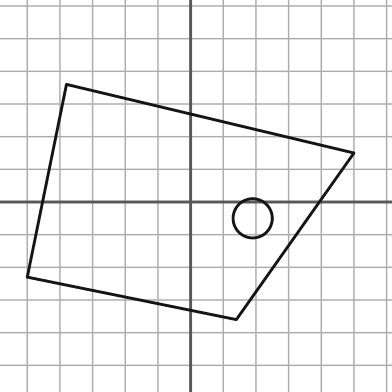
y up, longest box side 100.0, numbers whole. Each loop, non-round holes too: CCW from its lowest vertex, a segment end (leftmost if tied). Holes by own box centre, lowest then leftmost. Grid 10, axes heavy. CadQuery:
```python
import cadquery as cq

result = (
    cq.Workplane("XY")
    .moveTo(14.0, -36.0)
    .lineTo(50.0, 15.0)
    .lineTo(-38.0, 36.0)
    .lineTo(-50.0, -23.0)
    .close()
    .moveTo(19.0, -5.0)
    .circle(6.0)
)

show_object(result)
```